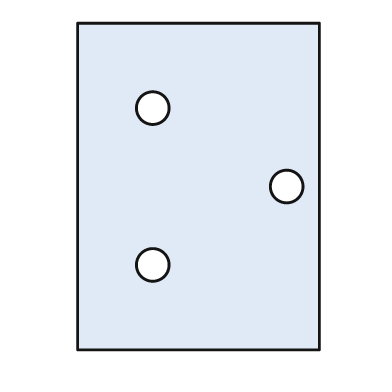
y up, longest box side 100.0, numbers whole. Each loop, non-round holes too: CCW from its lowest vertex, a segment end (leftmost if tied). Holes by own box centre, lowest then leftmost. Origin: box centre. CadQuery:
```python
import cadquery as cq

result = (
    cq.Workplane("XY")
    .moveTo(-37.0, -50.0)
    .lineTo(37.0, -50.0)
    .lineTo(37.0, 50.0)
    .lineTo(-37.0, 50.0)
    .close()
    .moveTo(-14.0, -24.0)
    .circle(5.0)
    .moveTo(27.0, 0.0)
    .circle(5.0)
    .moveTo(-14.0, 24.0)
    .circle(5.0)
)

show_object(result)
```